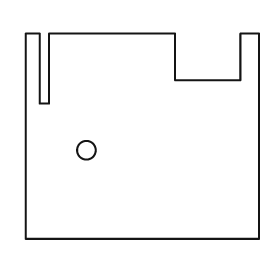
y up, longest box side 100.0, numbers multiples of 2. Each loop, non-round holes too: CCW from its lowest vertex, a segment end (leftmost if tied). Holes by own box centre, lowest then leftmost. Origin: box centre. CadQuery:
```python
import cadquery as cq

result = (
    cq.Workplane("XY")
    .moveTo(-50.0, -44.0)
    .lineTo(50.0, -44.0)
    .lineTo(50.0, 44.0)
    .lineTo(42.0, 44.0)
    .lineTo(42.0, 24.0)
    .lineTo(14.0, 24.0)
    .lineTo(14.0, 44.0)
    .lineTo(-40.0, 44.0)
    .lineTo(-40.0, 14.0)
    .lineTo(-44.0, 14.0)
    .lineTo(-44.0, 44.0)
    .lineTo(-50.0, 44.0)
    .close()
    .moveTo(-24.0, -6.0)
    .circle(4.0)
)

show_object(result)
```